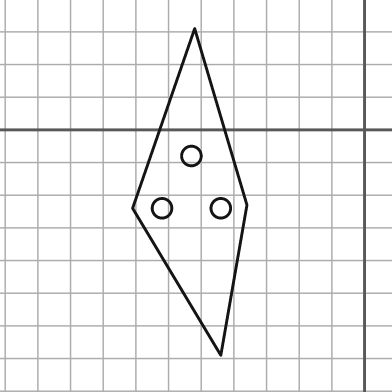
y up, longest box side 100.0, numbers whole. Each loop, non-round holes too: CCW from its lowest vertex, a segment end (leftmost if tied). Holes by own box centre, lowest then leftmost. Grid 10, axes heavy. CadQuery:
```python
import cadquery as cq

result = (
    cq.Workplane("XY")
    .moveTo(-44.0, -69.0)
    .lineTo(-36.0, -23.0)
    .lineTo(-52.0, 31.0)
    .lineTo(-71.0, -24.0)
    .close()
    .moveTo(-62.0, -24.0)
    .circle(3.0)
    .moveTo(-44.0, -24.0)
    .circle(3.0)
    .moveTo(-53.0, -8.0)
    .circle(3.0)
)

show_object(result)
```